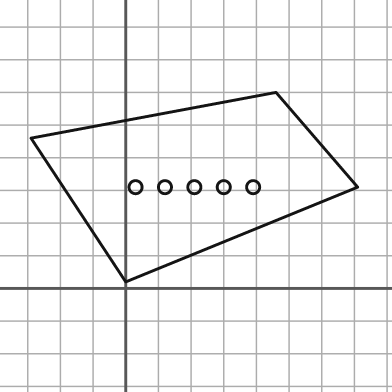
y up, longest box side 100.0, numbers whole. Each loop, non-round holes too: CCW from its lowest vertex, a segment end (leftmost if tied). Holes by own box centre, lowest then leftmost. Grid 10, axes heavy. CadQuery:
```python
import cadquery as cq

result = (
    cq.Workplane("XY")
    .moveTo(0.0, 2.0)
    .lineTo(71.0, 31.0)
    .lineTo(46.0, 60.0)
    .lineTo(-29.0, 46.0)
    .close()
    .moveTo(3.0, 31.0)
    .circle(2.0)
    .moveTo(12.0, 31.0)
    .circle(2.0)
    .moveTo(21.0, 31.0)
    .circle(2.0)
    .moveTo(30.0, 31.0)
    .circle(2.0)
    .moveTo(39.0, 31.0)
    .circle(2.0)
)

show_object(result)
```